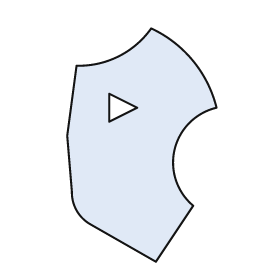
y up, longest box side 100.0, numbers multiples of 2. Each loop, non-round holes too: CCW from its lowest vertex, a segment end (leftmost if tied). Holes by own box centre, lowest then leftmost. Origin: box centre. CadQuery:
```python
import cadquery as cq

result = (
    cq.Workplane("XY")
    .moveTo(6.0, -50.0)
    .lineTo(22.0, -26.0)
    .threePointArc((14.0, -2.0), (32.0, 16.0))
    .threePointArc((22.0, 36.0), (4.0, 50.0))
    .threePointArc((-10.0, 38.0), (-28.0, 34.0))
    .lineTo(-32.0, 4.0)
    .lineTo(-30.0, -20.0)
    .threePointArc((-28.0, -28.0), (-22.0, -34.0))
    .close()
    .moveTo(-14.0, 10.0)
    .lineTo(-2.0, 16.0)
    .lineTo(-14.0, 22.0)
    .close()
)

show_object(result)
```